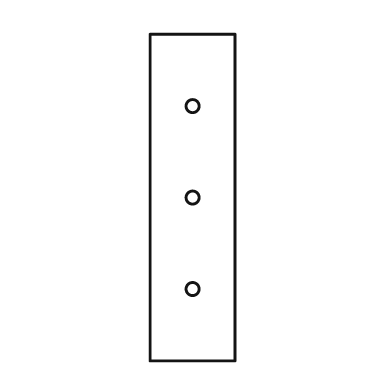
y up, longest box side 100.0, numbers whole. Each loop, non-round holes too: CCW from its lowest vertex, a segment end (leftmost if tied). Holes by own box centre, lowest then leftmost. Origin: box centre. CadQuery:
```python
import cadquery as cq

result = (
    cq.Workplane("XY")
    .moveTo(-13.0, -50.0)
    .lineTo(13.0, -50.0)
    .lineTo(13.0, 50.0)
    .lineTo(-13.0, 50.0)
    .close()
    .moveTo(0.0, -28.0)
    .circle(2.0)
    .moveTo(0.0, 0.0)
    .circle(2.0)
    .moveTo(0.0, 28.0)
    .circle(2.0)
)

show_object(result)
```